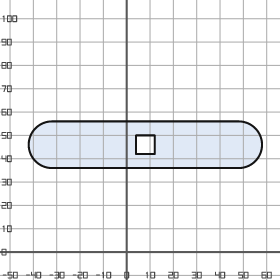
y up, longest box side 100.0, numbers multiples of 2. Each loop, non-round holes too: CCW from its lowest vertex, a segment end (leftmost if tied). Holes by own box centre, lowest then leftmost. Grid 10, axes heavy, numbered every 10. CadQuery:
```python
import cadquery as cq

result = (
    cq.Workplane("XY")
    .moveTo(-32.0, 36.0)
    .lineTo(48.0, 36.0)
    .threePointArc((58.0, 46.0), (48.0, 56.0))
    .lineTo(-32.0, 56.0)
    .threePointArc((-42.0, 46.0), (-32.0, 36.0))
    .close()
    .moveTo(4.0, 42.0)
    .lineTo(12.0, 42.0)
    .lineTo(12.0, 50.0)
    .lineTo(4.0, 50.0)
    .close()
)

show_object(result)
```